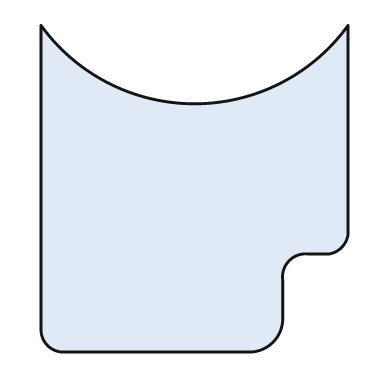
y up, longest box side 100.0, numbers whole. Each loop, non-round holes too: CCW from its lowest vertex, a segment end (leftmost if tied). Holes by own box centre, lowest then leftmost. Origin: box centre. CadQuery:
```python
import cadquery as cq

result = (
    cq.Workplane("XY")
    .moveTo(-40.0, -50.0)
    .lineTo(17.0, -50.0)
    .threePointArc((24.0, -47.0), (27.0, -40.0))
    .lineTo(27.0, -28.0)
    .threePointArc((29.0, -22.0), (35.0, -20.0))
    .lineTo(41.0, -20.0)
    .threePointArc((45.0, -18.0), (47.0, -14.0))
    .lineTo(47.0, 50.0)
    .threePointArc((0.0, 26.0), (-47.0, 50.0))
    .lineTo(-47.0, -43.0)
    .threePointArc((-45.0, -48.0), (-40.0, -50.0))
    .close()
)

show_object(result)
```